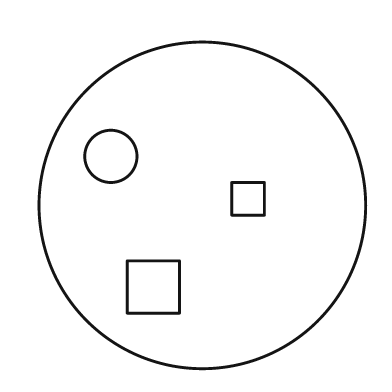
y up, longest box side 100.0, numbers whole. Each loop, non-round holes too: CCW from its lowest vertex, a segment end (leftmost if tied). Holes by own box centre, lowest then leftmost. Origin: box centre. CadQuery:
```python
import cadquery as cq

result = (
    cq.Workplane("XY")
    .moveTo(0.0, 0.0)
    .circle(50.0)
    .moveTo(-23.0, -33.0)
    .lineTo(-7.0, -33.0)
    .lineTo(-7.0, -17.0)
    .lineTo(-23.0, -17.0)
    .close()
    .moveTo(9.0, -3.0)
    .lineTo(19.0, -3.0)
    .lineTo(19.0, 7.0)
    .lineTo(9.0, 7.0)
    .close()
    .moveTo(-28.0, 15.0)
    .circle(8.0)
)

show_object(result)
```